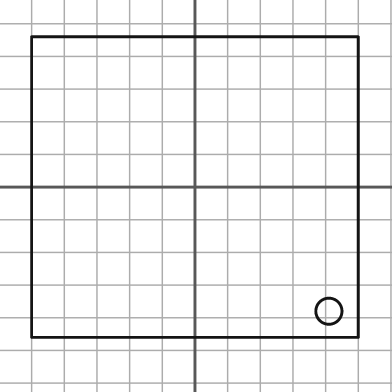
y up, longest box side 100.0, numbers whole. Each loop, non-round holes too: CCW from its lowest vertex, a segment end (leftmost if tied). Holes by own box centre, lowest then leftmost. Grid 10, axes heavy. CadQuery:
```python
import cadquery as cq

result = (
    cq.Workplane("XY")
    .moveTo(-50.0, -46.0)
    .lineTo(50.0, -46.0)
    .lineTo(50.0, 46.0)
    .lineTo(-50.0, 46.0)
    .close()
    .moveTo(41.0, -38.0)
    .circle(4.0)
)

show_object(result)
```